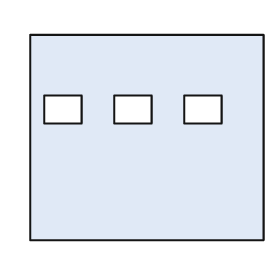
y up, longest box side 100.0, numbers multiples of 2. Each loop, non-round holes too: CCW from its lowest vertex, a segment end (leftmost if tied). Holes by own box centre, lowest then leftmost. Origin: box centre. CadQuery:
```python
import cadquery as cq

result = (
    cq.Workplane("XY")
    .moveTo(-50.0, -44.0)
    .lineTo(50.0, -44.0)
    .lineTo(50.0, 44.0)
    .lineTo(-50.0, 44.0)
    .close()
    .moveTo(-44.0, 6.0)
    .lineTo(-28.0, 6.0)
    .lineTo(-28.0, 18.0)
    .lineTo(-44.0, 18.0)
    .close()
    .moveTo(-14.0, 6.0)
    .lineTo(2.0, 6.0)
    .lineTo(2.0, 18.0)
    .lineTo(-14.0, 18.0)
    .close()
    .moveTo(16.0, 6.0)
    .lineTo(32.0, 6.0)
    .lineTo(32.0, 18.0)
    .lineTo(16.0, 18.0)
    .close()
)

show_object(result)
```